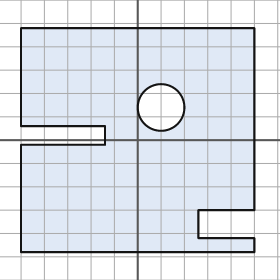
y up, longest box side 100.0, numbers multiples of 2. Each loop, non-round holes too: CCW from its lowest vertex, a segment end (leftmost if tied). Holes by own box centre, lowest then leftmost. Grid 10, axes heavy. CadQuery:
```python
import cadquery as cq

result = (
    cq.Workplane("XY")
    .moveTo(-50.0, -48.0)
    .lineTo(50.0, -48.0)
    .lineTo(50.0, -42.0)
    .lineTo(26.0, -42.0)
    .lineTo(26.0, -30.0)
    .lineTo(50.0, -30.0)
    .lineTo(50.0, 48.0)
    .lineTo(-50.0, 48.0)
    .lineTo(-50.0, 6.0)
    .lineTo(-14.0, 6.0)
    .lineTo(-14.0, -2.0)
    .lineTo(-50.0, -2.0)
    .close()
    .moveTo(10.0, 14.0)
    .circle(10.0)
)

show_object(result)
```